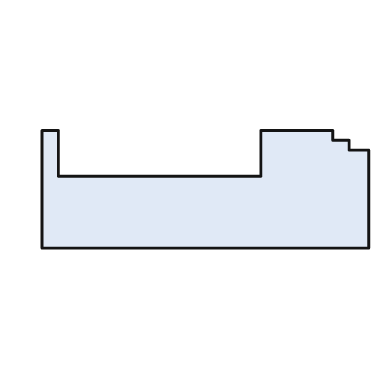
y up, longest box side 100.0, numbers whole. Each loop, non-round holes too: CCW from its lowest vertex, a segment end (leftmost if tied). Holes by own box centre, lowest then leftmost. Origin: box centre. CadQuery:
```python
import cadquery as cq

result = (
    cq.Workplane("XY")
    .moveTo(-50.0, -18.0)
    .lineTo(50.0, -18.0)
    .lineTo(50.0, 12.0)
    .lineTo(44.0, 12.0)
    .lineTo(44.0, 15.0)
    .lineTo(39.0, 15.0)
    .lineTo(39.0, 18.0)
    .lineTo(17.0, 18.0)
    .lineTo(17.0, 4.0)
    .lineTo(-45.0, 4.0)
    .lineTo(-45.0, 18.0)
    .lineTo(-50.0, 18.0)
    .close()
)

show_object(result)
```